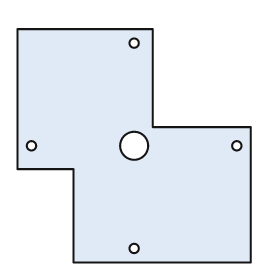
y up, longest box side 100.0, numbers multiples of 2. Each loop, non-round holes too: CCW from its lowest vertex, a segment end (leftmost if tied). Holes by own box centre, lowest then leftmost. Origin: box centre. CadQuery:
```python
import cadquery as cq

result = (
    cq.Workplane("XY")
    .moveTo(-26.0, -50.0)
    .lineTo(50.0, -50.0)
    .lineTo(50.0, 8.0)
    .lineTo(8.0, 8.0)
    .lineTo(8.0, 50.0)
    .lineTo(-50.0, 50.0)
    .lineTo(-50.0, -10.0)
    .lineTo(-26.0, -10.0)
    .close()
    .moveTo(0.0, -44.0)
    .circle(2.0)
    .moveTo(-44.0, 0.0)
    .circle(2.0)
    .moveTo(0.0, 0.0)
    .circle(6.0)
    .moveTo(44.0, 0.0)
    .circle(2.0)
    .moveTo(0.0, 44.0)
    .circle(2.0)
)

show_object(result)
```